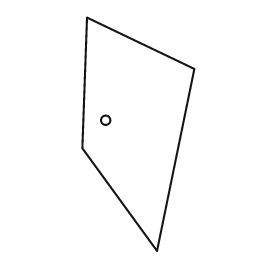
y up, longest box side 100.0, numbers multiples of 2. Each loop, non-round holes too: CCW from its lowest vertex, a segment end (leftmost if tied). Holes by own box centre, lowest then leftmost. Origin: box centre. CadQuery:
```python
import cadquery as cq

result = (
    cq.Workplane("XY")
    .moveTo(8.0, -50.0)
    .lineTo(24.0, 28.0)
    .lineTo(-22.0, 50.0)
    .lineTo(-24.0, -6.0)
    .close()
    .moveTo(-14.0, 6.0)
    .circle(2.0)
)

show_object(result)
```